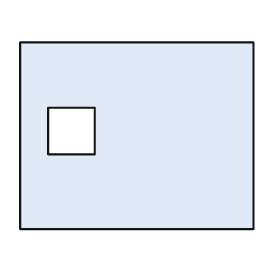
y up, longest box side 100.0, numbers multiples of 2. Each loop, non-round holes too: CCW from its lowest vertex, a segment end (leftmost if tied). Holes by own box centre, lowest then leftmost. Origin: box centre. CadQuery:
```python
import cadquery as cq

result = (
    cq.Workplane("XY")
    .moveTo(-50.0, -40.0)
    .lineTo(50.0, -40.0)
    .lineTo(50.0, 40.0)
    .lineTo(-50.0, 40.0)
    .close()
    .moveTo(-38.0, -8.0)
    .lineTo(-18.0, -8.0)
    .lineTo(-18.0, 12.0)
    .lineTo(-38.0, 12.0)
    .close()
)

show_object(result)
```